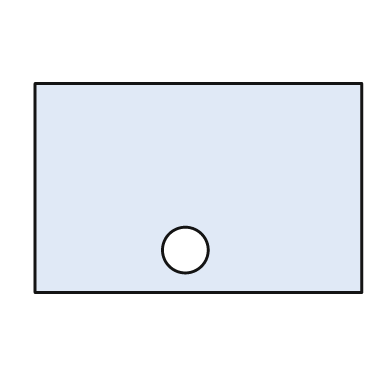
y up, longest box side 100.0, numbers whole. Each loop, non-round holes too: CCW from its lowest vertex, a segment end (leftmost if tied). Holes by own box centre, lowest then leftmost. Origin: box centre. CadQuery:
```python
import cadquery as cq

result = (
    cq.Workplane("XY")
    .moveTo(-50.0, -32.0)
    .lineTo(50.0, -32.0)
    .lineTo(50.0, 32.0)
    .lineTo(-50.0, 32.0)
    .close()
    .moveTo(-4.0, -19.0)
    .circle(7.0)
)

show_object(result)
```